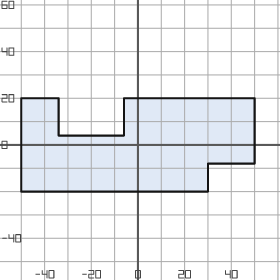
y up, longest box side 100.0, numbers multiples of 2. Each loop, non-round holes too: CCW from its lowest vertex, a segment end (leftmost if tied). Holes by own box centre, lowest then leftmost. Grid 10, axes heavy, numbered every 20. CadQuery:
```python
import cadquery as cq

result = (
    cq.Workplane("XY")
    .moveTo(-50.0, -20.0)
    .lineTo(30.0, -20.0)
    .lineTo(30.0, -8.0)
    .lineTo(50.0, -8.0)
    .lineTo(50.0, 20.0)
    .lineTo(-6.0, 20.0)
    .lineTo(-6.0, 4.0)
    .lineTo(-34.0, 4.0)
    .lineTo(-34.0, 20.0)
    .lineTo(-50.0, 20.0)
    .close()
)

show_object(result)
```